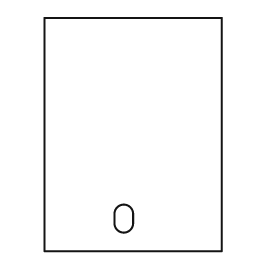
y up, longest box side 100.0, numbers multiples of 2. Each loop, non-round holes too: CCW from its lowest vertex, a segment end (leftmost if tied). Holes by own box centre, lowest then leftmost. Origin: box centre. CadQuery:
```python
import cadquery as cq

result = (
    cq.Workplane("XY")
    .moveTo(-38.0, -50.0)
    .lineTo(38.0, -50.0)
    .lineTo(38.0, 50.0)
    .lineTo(-38.0, 50.0)
    .close()
    .moveTo(-8.0, -38.0)
    .threePointArc((-4.0, -42.0), (0.0, -38.0))
    .lineTo(0.0, -34.0)
    .threePointArc((-4.0, -30.0), (-8.0, -34.0))
    .close()
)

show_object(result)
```